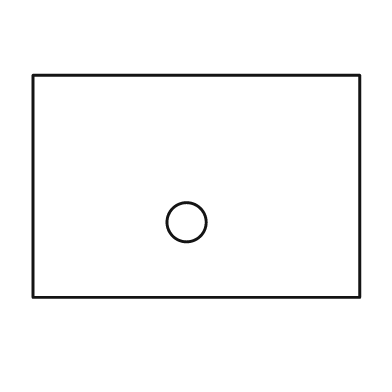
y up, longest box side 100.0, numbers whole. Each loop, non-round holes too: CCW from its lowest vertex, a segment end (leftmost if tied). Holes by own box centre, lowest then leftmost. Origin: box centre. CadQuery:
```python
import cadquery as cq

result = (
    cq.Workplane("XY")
    .moveTo(-50.0, -34.0)
    .lineTo(50.0, -34.0)
    .lineTo(50.0, 34.0)
    .lineTo(-50.0, 34.0)
    .close()
    .moveTo(-3.0, -11.0)
    .circle(6.0)
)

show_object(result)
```